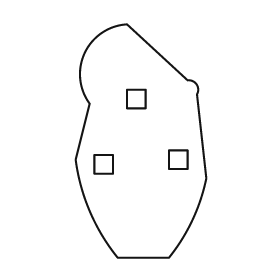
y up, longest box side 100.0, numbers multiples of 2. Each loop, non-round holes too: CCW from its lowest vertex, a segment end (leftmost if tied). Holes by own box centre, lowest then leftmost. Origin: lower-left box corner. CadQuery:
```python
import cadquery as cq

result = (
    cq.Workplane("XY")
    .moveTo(18.0, 0.0)
    .lineTo(40.0, 0.0)
    .threePointArc((50.0, 16.0), (56.0, 34.0))
    .lineTo(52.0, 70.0)
    .threePointArc((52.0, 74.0), (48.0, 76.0))
    .lineTo(22.0, 100.0)
    .threePointArc((4.0, 88.0), (6.0, 66.0))
    .lineTo(0.0, 42.0)
    .threePointArc((6.0, 20.0), (18.0, 0.0))
    .close()
    .moveTo(8.0, 36.0)
    .lineTo(16.0, 36.0)
    .lineTo(16.0, 44.0)
    .lineTo(8.0, 44.0)
    .close()
    .moveTo(40.0, 38.0)
    .lineTo(48.0, 38.0)
    .lineTo(48.0, 46.0)
    .lineTo(40.0, 46.0)
    .close()
    .moveTo(22.0, 64.0)
    .lineTo(30.0, 64.0)
    .lineTo(30.0, 72.0)
    .lineTo(22.0, 72.0)
    .close()
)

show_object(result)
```